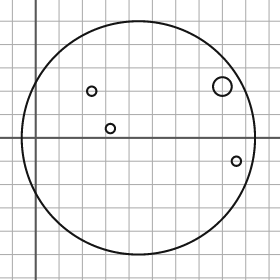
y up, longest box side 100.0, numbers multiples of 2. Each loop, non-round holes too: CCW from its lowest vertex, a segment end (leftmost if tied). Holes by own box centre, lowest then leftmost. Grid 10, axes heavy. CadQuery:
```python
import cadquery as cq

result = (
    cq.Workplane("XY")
    .moveTo(44.0, 0.0)
    .circle(50.0)
    .moveTo(86.0, -10.0)
    .circle(2.0)
    .moveTo(32.0, 4.0)
    .circle(2.0)
    .moveTo(24.0, 20.0)
    .circle(2.0)
    .moveTo(80.0, 22.0)
    .circle(4.0)
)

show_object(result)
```